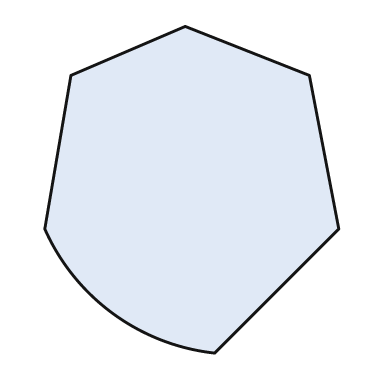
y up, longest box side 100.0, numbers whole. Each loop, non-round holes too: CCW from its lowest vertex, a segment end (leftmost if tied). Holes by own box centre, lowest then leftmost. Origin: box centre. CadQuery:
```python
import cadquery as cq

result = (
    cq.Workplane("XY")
    .moveTo(7.0, -50.0)
    .lineTo(45.0, -12.0)
    .lineTo(36.0, 35.0)
    .lineTo(-2.0, 50.0)
    .lineTo(-37.0, 35.0)
    .lineTo(-45.0, -12.0)
    .threePointArc((-24.0, -38.0), (7.0, -50.0))
    .close()
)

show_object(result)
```